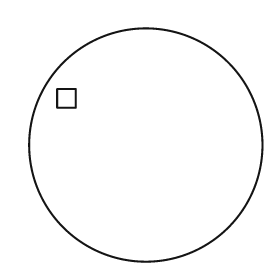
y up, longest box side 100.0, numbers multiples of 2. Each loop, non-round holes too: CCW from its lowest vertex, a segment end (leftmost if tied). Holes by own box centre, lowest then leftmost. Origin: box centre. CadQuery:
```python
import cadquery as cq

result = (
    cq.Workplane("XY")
    .moveTo(0.0, 0.0)
    .circle(50.0)
    .moveTo(-38.0, 16.0)
    .lineTo(-30.0, 16.0)
    .lineTo(-30.0, 24.0)
    .lineTo(-38.0, 24.0)
    .close()
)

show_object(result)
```